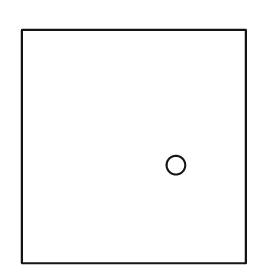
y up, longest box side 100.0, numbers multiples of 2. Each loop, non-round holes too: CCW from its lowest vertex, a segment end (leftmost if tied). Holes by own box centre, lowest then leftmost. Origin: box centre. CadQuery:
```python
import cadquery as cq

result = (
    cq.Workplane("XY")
    .moveTo(-48.0, -50.0)
    .lineTo(48.0, -50.0)
    .lineTo(48.0, 50.0)
    .lineTo(-48.0, 50.0)
    .close()
    .moveTo(18.0, -8.0)
    .circle(4.0)
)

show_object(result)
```